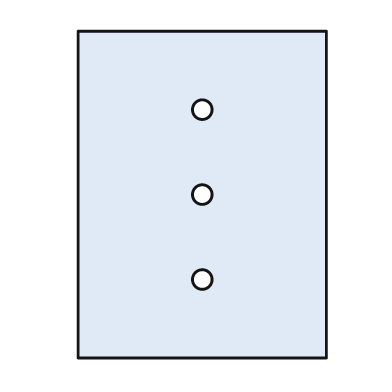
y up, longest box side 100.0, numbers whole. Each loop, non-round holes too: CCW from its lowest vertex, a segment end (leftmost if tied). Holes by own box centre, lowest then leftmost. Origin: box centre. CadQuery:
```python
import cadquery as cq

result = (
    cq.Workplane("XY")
    .moveTo(-38.0, -50.0)
    .lineTo(38.0, -50.0)
    .lineTo(38.0, 50.0)
    .lineTo(-38.0, 50.0)
    .close()
    .moveTo(0.0, -26.0)
    .circle(3.0)
    .moveTo(0.0, 0.0)
    .circle(3.0)
    .moveTo(0.0, 26.0)
    .circle(3.0)
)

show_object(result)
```